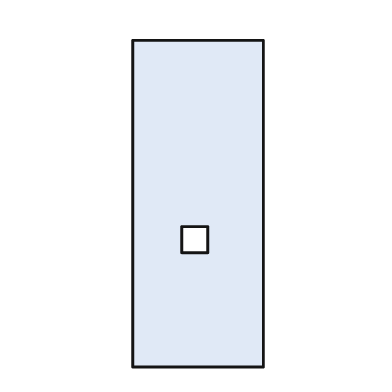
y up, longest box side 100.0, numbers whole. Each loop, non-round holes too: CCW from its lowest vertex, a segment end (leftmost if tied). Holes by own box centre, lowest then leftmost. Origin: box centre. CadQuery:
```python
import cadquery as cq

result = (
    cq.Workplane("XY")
    .moveTo(-20.0, -50.0)
    .lineTo(20.0, -50.0)
    .lineTo(20.0, 50.0)
    .lineTo(-20.0, 50.0)
    .close()
    .moveTo(-5.0, -15.0)
    .lineTo(3.0, -15.0)
    .lineTo(3.0, -7.0)
    .lineTo(-5.0, -7.0)
    .close()
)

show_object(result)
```